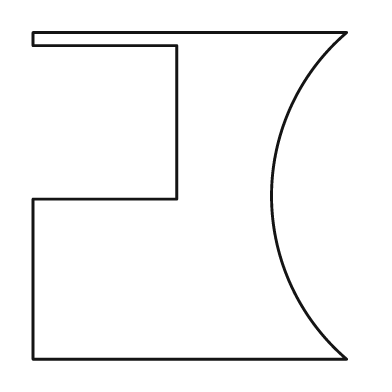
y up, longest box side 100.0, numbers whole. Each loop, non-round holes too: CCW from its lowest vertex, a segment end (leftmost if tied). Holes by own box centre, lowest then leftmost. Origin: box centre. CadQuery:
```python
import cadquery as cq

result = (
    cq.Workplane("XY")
    .moveTo(-48.0, -50.0)
    .lineTo(48.0, -50.0)
    .threePointArc((25.0, 0.0), (48.0, 50.0))
    .lineTo(-48.0, 50.0)
    .lineTo(-48.0, 46.0)
    .lineTo(-4.0, 46.0)
    .lineTo(-4.0, -1.0)
    .lineTo(-48.0, -1.0)
    .close()
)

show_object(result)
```